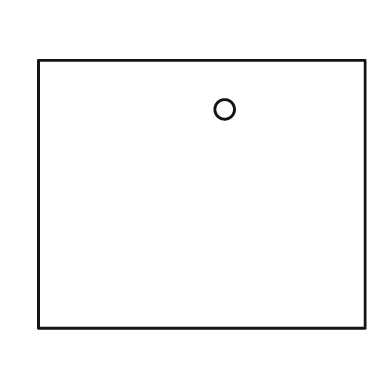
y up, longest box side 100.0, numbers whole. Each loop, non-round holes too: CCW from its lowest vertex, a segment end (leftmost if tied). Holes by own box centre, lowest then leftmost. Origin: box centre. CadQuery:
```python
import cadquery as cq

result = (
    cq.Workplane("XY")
    .moveTo(-50.0, -41.0)
    .lineTo(50.0, -41.0)
    .lineTo(50.0, 41.0)
    .lineTo(-50.0, 41.0)
    .close()
    .moveTo(7.0, 26.0)
    .circle(3.0)
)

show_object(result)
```